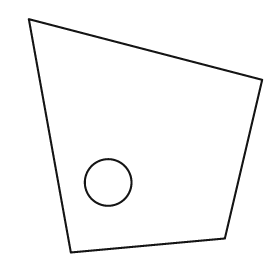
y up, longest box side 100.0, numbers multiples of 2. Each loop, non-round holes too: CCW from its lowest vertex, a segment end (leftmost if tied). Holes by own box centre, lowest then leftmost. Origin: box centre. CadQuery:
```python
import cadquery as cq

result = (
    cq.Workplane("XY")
    .moveTo(-32.0, -50.0)
    .lineTo(34.0, -44.0)
    .lineTo(50.0, 24.0)
    .lineTo(-50.0, 50.0)
    .close()
    .moveTo(-16.0, -20.0)
    .circle(10.0)
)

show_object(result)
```